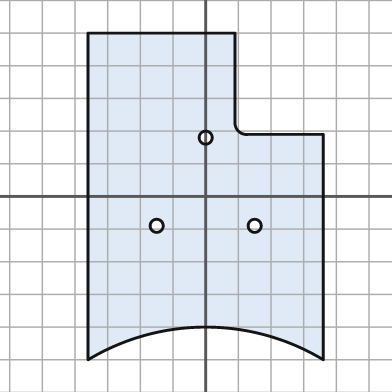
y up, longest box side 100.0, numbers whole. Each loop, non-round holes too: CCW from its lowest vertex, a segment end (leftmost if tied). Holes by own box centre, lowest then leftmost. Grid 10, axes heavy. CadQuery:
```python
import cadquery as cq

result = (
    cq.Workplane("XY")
    .moveTo(-36.0, -50.0)
    .threePointArc((0.0, -40.0), (36.0, -50.0))
    .lineTo(36.0, 19.0)
    .lineTo(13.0, 19.0)
    .threePointArc((10.0, 20.0), (9.0, 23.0))
    .lineTo(9.0, 50.0)
    .lineTo(-36.0, 50.0)
    .close()
    .moveTo(-15.0, -9.0)
    .circle(2.0)
    .moveTo(15.0, -9.0)
    .circle(2.0)
    .moveTo(0.0, 18.0)
    .circle(2.0)
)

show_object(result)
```